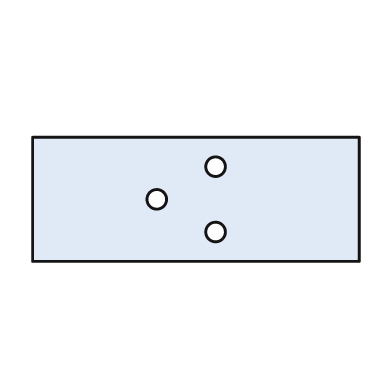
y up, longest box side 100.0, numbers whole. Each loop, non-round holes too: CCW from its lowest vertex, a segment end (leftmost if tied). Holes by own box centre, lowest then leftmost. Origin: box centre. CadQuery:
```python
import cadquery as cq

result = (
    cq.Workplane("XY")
    .moveTo(-50.0, -19.0)
    .lineTo(50.0, -19.0)
    .lineTo(50.0, 19.0)
    .lineTo(-50.0, 19.0)
    .close()
    .moveTo(6.0, -10.0)
    .circle(3.0)
    .moveTo(-12.0, 0.0)
    .circle(3.0)
    .moveTo(6.0, 10.0)
    .circle(3.0)
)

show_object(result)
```